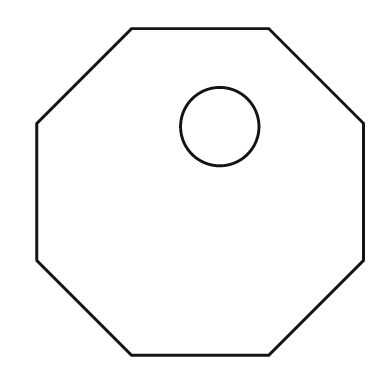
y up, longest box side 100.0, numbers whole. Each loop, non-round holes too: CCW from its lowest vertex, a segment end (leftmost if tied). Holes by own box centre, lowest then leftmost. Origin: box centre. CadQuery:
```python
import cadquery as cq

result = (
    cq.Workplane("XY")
    .moveTo(-21.0, -50.0)
    .lineTo(21.0, -50.0)
    .lineTo(50.0, -21.0)
    .lineTo(50.0, 21.0)
    .lineTo(21.0, 50.0)
    .lineTo(-21.0, 50.0)
    .lineTo(-50.0, 21.0)
    .lineTo(-50.0, -21.0)
    .close()
    .moveTo(6.0, 20.0)
    .circle(12.0)
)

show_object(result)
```